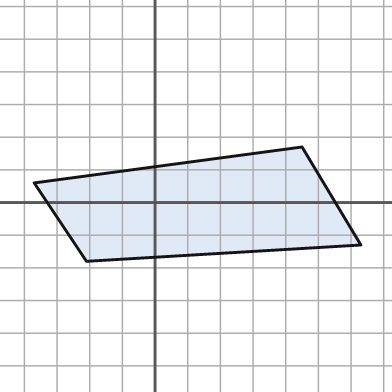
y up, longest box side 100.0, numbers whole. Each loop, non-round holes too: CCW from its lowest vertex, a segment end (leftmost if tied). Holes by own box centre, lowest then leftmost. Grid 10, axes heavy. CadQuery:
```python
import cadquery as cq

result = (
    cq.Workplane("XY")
    .moveTo(-21.0, -18.0)
    .lineTo(63.0, -13.0)
    .lineTo(45.0, 17.0)
    .lineTo(-37.0, 6.0)
    .close()
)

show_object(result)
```